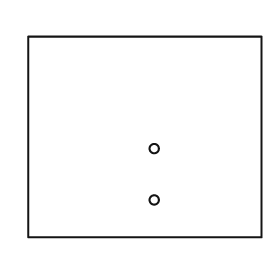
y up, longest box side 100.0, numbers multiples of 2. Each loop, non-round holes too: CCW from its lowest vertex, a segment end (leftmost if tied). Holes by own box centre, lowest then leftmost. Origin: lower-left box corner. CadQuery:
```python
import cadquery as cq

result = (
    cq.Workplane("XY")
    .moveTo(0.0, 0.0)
    .lineTo(100.0, 0.0)
    .lineTo(100.0, 86.0)
    .lineTo(0.0, 86.0)
    .close()
    .moveTo(54.0, 16.0)
    .circle(2.0)
    .moveTo(54.0, 38.0)
    .circle(2.0)
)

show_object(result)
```